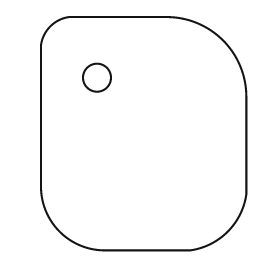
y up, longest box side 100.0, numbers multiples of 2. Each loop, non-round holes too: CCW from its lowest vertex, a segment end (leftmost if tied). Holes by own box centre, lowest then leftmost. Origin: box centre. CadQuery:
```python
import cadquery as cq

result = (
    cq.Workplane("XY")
    .moveTo(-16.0, -50.0)
    .lineTo(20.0, -50.0)
    .threePointArc((36.0, -42.0), (44.0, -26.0))
    .lineTo(44.0, 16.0)
    .threePointArc((34.0, 40.0), (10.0, 50.0))
    .lineTo(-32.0, 50.0)
    .threePointArc((-40.0, 46.0), (-44.0, 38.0))
    .lineTo(-44.0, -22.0)
    .threePointArc((-36.0, -42.0), (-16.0, -50.0))
    .close()
    .moveTo(-20.0, 24.0)
    .circle(6.0)
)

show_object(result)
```